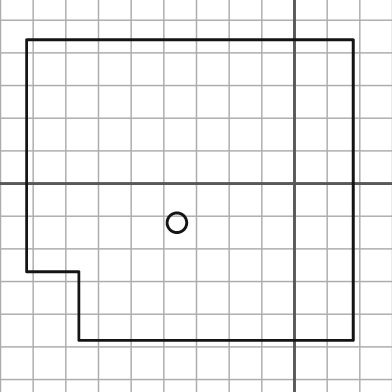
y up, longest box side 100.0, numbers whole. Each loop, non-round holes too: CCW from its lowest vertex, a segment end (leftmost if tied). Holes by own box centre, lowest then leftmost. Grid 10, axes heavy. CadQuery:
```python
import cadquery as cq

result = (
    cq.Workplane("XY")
    .moveTo(-66.0, -48.0)
    .lineTo(18.0, -48.0)
    .lineTo(18.0, 44.0)
    .lineTo(-82.0, 44.0)
    .lineTo(-82.0, -27.0)
    .lineTo(-66.0, -27.0)
    .close()
    .moveTo(-36.0, -12.0)
    .circle(3.0)
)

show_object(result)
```